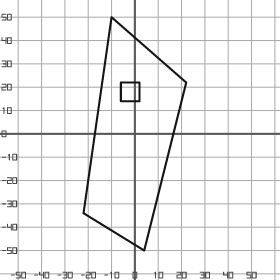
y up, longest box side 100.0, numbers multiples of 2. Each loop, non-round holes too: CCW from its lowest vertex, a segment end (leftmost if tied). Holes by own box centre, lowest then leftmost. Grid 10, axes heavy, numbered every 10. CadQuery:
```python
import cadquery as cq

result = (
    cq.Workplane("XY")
    .moveTo(4.0, -50.0)
    .lineTo(22.0, 22.0)
    .lineTo(-10.0, 50.0)
    .lineTo(-22.0, -34.0)
    .close()
    .moveTo(-6.0, 14.0)
    .lineTo(2.0, 14.0)
    .lineTo(2.0, 22.0)
    .lineTo(-6.0, 22.0)
    .close()
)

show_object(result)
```